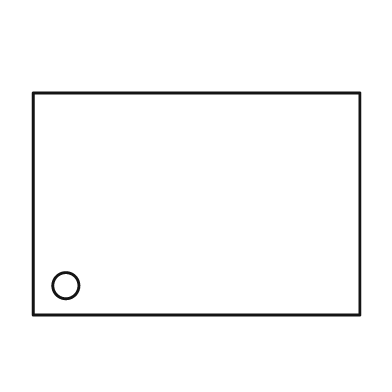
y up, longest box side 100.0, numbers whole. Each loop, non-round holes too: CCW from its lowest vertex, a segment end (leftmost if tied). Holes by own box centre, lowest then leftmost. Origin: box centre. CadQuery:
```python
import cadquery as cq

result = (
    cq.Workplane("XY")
    .moveTo(-50.0, -34.0)
    .lineTo(50.0, -34.0)
    .lineTo(50.0, 34.0)
    .lineTo(-50.0, 34.0)
    .close()
    .moveTo(-40.0, -25.0)
    .circle(4.0)
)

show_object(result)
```